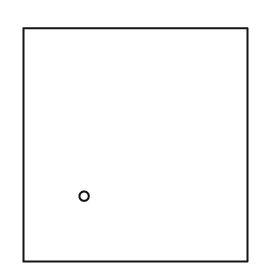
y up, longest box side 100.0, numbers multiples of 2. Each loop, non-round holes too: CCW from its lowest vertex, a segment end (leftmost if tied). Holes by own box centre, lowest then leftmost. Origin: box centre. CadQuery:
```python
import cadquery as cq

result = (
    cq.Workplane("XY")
    .moveTo(-48.0, -50.0)
    .lineTo(48.0, -50.0)
    .lineTo(48.0, 50.0)
    .lineTo(-48.0, 50.0)
    .close()
    .moveTo(-22.0, -22.0)
    .circle(2.0)
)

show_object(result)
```